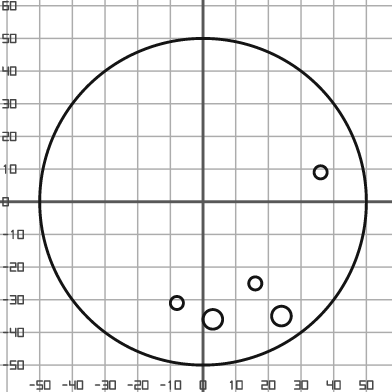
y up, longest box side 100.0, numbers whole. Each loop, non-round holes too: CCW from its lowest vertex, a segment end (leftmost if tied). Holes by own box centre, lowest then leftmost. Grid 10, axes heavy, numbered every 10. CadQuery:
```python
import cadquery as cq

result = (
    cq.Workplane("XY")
    .moveTo(0.0, 0.0)
    .circle(50.0)
    .moveTo(3.0, -36.0)
    .circle(3.0)
    .moveTo(24.0, -35.0)
    .circle(3.0)
    .moveTo(-8.0, -31.0)
    .circle(2.0)
    .moveTo(16.0, -25.0)
    .circle(2.0)
    .moveTo(36.0, 9.0)
    .circle(2.0)
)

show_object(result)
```